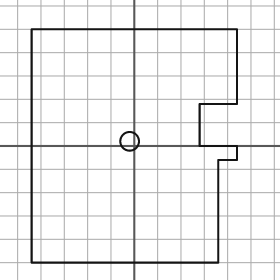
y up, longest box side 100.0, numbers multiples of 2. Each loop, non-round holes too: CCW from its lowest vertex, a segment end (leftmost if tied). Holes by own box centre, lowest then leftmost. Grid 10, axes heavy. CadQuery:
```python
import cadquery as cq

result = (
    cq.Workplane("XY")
    .moveTo(-44.0, -50.0)
    .lineTo(36.0, -50.0)
    .lineTo(36.0, -6.0)
    .lineTo(44.0, -6.0)
    .lineTo(44.0, 0.0)
    .lineTo(28.0, 0.0)
    .lineTo(28.0, 18.0)
    .lineTo(44.0, 18.0)
    .lineTo(44.0, 50.0)
    .lineTo(-44.0, 50.0)
    .close()
    .moveTo(-2.0, 2.0)
    .circle(4.0)
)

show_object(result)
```